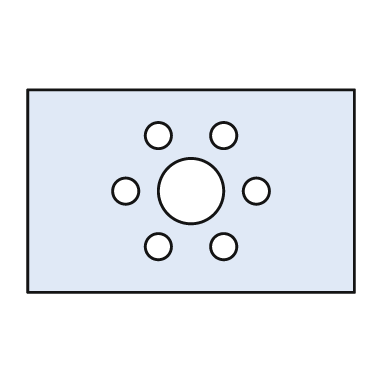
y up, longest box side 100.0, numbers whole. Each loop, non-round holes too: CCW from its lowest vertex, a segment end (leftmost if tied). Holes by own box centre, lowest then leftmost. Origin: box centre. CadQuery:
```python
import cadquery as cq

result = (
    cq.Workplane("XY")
    .moveTo(-50.0, -31.0)
    .lineTo(50.0, -31.0)
    .lineTo(50.0, 31.0)
    .lineTo(-50.0, 31.0)
    .close()
    .moveTo(-10.0, -17.0)
    .circle(4.0)
    .moveTo(10.0, -17.0)
    .circle(4.0)
    .moveTo(-20.0, 0.0)
    .circle(4.0)
    .moveTo(0.0, 0.0)
    .circle(10.0)
    .moveTo(20.0, 0.0)
    .circle(4.0)
    .moveTo(-10.0, 17.0)
    .circle(4.0)
    .moveTo(10.0, 17.0)
    .circle(4.0)
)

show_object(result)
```